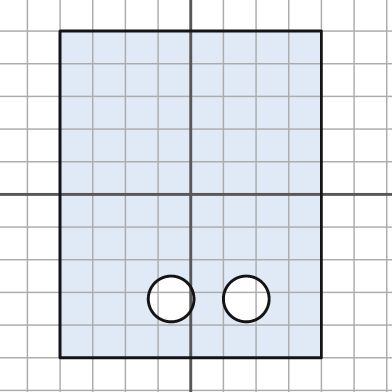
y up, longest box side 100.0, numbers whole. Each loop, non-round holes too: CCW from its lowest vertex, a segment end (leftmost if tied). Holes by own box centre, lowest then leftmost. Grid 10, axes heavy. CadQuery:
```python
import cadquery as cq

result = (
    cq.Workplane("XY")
    .moveTo(-40.0, -50.0)
    .lineTo(40.0, -50.0)
    .lineTo(40.0, 50.0)
    .lineTo(-40.0, 50.0)
    .close()
    .moveTo(-6.0, -32.0)
    .circle(7.0)
    .moveTo(17.0, -32.0)
    .circle(7.0)
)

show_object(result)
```